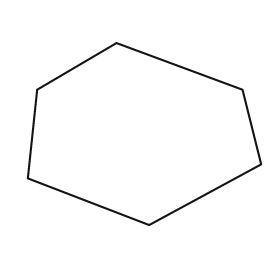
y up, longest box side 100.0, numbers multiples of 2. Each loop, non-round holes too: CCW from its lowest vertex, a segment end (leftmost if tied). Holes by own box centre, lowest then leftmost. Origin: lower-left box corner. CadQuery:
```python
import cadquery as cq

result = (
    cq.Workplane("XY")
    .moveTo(52.0, 0.0)
    .lineTo(100.0, 26.0)
    .lineTo(92.0, 58.0)
    .lineTo(38.0, 78.0)
    .lineTo(4.0, 58.0)
    .lineTo(0.0, 20.0)
    .close()
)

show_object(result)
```